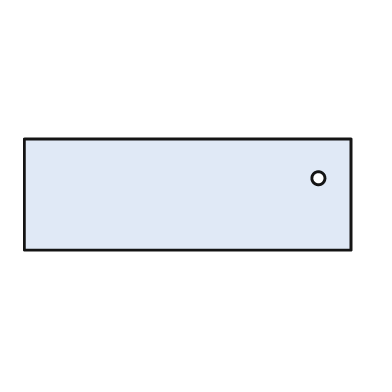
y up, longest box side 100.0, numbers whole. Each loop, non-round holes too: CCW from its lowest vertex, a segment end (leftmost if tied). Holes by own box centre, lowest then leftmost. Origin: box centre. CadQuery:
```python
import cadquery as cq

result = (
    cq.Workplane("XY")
    .moveTo(-50.0, -17.0)
    .lineTo(50.0, -17.0)
    .lineTo(50.0, 17.0)
    .lineTo(-50.0, 17.0)
    .close()
    .moveTo(40.0, 5.0)
    .circle(2.0)
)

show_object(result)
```